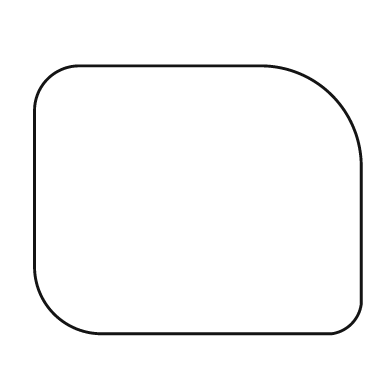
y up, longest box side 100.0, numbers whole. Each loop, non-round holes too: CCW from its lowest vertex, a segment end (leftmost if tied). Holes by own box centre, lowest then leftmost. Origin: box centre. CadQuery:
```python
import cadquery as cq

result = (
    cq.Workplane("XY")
    .moveTo(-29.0, -41.0)
    .lineTo(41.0, -41.0)
    .threePointArc((47.0, -38.0), (50.0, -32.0))
    .lineTo(50.0, 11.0)
    .threePointArc((41.0, 32.0), (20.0, 41.0))
    .lineTo(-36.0, 41.0)
    .threePointArc((-46.0, 37.0), (-50.0, 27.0))
    .lineTo(-50.0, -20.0)
    .threePointArc((-44.0, -35.0), (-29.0, -41.0))
    .close()
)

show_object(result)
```